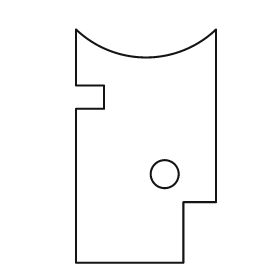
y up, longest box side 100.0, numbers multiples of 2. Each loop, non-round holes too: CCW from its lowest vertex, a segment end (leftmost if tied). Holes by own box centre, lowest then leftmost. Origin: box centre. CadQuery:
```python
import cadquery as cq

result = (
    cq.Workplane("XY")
    .moveTo(-30.0, -50.0)
    .lineTo(16.0, -50.0)
    .lineTo(16.0, -24.0)
    .lineTo(30.0, -24.0)
    .lineTo(30.0, 50.0)
    .threePointArc((0.0, 38.0), (-30.0, 50.0))
    .lineTo(-30.0, 26.0)
    .lineTo(-18.0, 26.0)
    .lineTo(-18.0, 16.0)
    .lineTo(-30.0, 16.0)
    .close()
    .moveTo(8.0, -12.0)
    .circle(6.0)
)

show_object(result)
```